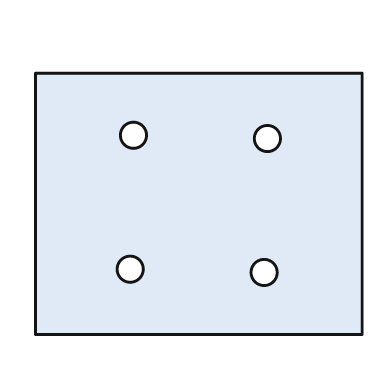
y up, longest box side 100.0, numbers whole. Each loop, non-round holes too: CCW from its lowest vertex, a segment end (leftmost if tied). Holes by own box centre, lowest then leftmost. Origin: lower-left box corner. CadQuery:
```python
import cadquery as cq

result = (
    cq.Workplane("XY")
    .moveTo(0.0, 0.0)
    .lineTo(100.0, 0.0)
    .lineTo(100.0, 80.0)
    .lineTo(0.0, 80.0)
    .close()
    .moveTo(70.0, 19.0)
    .circle(4.0)
    .moveTo(29.0, 20.0)
    .circle(4.0)
    .moveTo(71.0, 60.0)
    .circle(4.0)
    .moveTo(30.0, 61.0)
    .circle(4.0)
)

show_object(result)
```